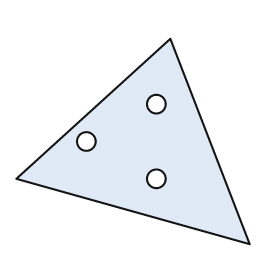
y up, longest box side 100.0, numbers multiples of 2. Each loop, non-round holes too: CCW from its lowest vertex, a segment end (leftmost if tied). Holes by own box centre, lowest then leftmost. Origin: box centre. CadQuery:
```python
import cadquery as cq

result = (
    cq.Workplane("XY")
    .moveTo(50.0, -44.0)
    .lineTo(16.0, 44.0)
    .lineTo(-50.0, -16.0)
    .close()
    .moveTo(10.0, -16.0)
    .circle(4.0)
    .moveTo(-20.0, 0.0)
    .circle(4.0)
    .moveTo(10.0, 16.0)
    .circle(4.0)
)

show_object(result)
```